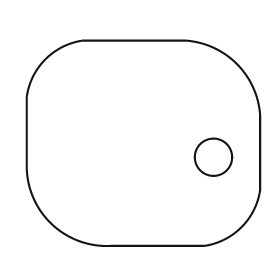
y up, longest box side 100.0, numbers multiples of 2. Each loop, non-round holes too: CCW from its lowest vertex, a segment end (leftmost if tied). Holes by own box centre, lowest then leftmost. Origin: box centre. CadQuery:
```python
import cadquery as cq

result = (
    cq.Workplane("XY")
    .moveTo(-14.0, -44.0)
    .lineTo(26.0, -44.0)
    .threePointArc((42.0, -36.0), (50.0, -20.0))
    .lineTo(50.0, 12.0)
    .threePointArc((40.0, 34.0), (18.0, 44.0))
    .lineTo(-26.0, 44.0)
    .threePointArc((-42.0, 36.0), (-50.0, 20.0))
    .lineTo(-50.0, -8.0)
    .threePointArc((-40.0, -34.0), (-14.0, -44.0))
    .close()
    .moveTo(30.0, -6.0)
    .circle(8.0)
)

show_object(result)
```